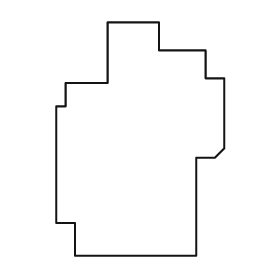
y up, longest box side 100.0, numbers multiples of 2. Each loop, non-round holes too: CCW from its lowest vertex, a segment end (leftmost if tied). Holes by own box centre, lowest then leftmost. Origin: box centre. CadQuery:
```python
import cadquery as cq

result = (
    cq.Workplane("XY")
    .moveTo(-28.0, -50.0)
    .lineTo(24.0, -50.0)
    .lineTo(24.0, -8.0)
    .lineTo(32.0, -8.0)
    .lineTo(36.0, -4.0)
    .lineTo(36.0, 26.0)
    .lineTo(28.0, 26.0)
    .lineTo(28.0, 38.0)
    .lineTo(8.0, 38.0)
    .lineTo(8.0, 50.0)
    .lineTo(-14.0, 50.0)
    .lineTo(-14.0, 24.0)
    .lineTo(-32.0, 24.0)
    .lineTo(-32.0, 14.0)
    .lineTo(-36.0, 14.0)
    .lineTo(-36.0, -36.0)
    .lineTo(-28.0, -36.0)
    .close()
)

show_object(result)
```